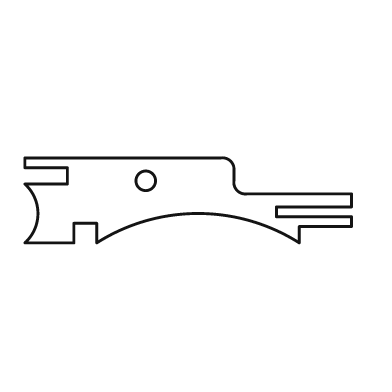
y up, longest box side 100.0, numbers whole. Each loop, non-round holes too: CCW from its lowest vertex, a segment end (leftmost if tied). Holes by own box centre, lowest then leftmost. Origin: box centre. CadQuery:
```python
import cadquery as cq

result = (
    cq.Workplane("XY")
    .moveTo(-50.0, -13.0)
    .lineTo(-35.0, -13.0)
    .lineTo(-35.0, -7.0)
    .lineTo(-28.0, -7.0)
    .lineTo(-28.0, -13.0)
    .threePointArc((3.0, -4.0), (34.0, -13.0))
    .lineTo(34.0, -8.0)
    .lineTo(50.0, -8.0)
    .lineTo(50.0, -5.0)
    .lineTo(27.0, -5.0)
    .lineTo(27.0, -2.0)
    .lineTo(50.0, -2.0)
    .lineTo(50.0, 2.0)
    .lineTo(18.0, 2.0)
    .threePointArc((15.0, 3.0), (14.0, 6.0))
    .lineTo(14.0, 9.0)
    .threePointArc((13.0, 12.0), (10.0, 13.0))
    .lineTo(-50.0, 13.0)
    .lineTo(-50.0, 10.0)
    .lineTo(-37.0, 10.0)
    .lineTo(-37.0, 5.0)
    .lineTo(-50.0, 5.0)
    .threePointArc((-46.0, -4.0), (-50.0, -13.0))
    .close()
    .moveTo(-13.0, 6.0)
    .circle(3.0)
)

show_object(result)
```